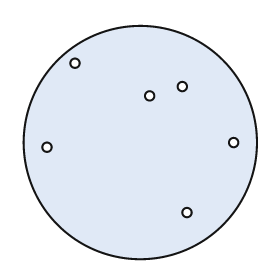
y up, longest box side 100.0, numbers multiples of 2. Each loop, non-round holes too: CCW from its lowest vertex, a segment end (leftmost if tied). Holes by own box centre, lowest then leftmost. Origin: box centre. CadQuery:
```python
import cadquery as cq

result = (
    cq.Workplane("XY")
    .moveTo(0.0, 0.0)
    .circle(50.0)
    .moveTo(20.0, -30.0)
    .circle(2.0)
    .moveTo(-40.0, -2.0)
    .circle(2.0)
    .moveTo(40.0, 0.0)
    .circle(2.0)
    .moveTo(4.0, 20.0)
    .circle(2.0)
    .moveTo(18.0, 24.0)
    .circle(2.0)
    .moveTo(-28.0, 34.0)
    .circle(2.0)
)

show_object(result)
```